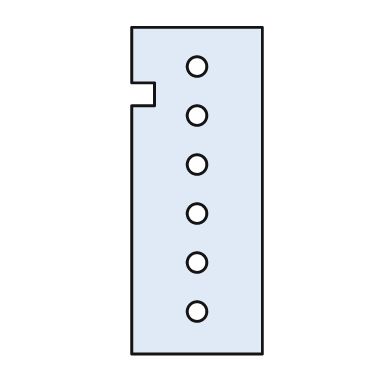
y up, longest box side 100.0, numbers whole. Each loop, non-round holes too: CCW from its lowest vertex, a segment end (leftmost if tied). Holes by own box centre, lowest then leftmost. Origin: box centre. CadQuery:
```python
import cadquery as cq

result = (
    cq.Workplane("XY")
    .moveTo(-20.0, -50.0)
    .lineTo(20.0, -50.0)
    .lineTo(20.0, 50.0)
    .lineTo(-20.0, 50.0)
    .lineTo(-20.0, 33.0)
    .lineTo(-13.0, 33.0)
    .lineTo(-13.0, 26.0)
    .lineTo(-20.0, 26.0)
    .close()
    .moveTo(0.0, -37.0)
    .circle(3.0)
    .moveTo(0.0, -22.0)
    .circle(3.0)
    .moveTo(0.0, -7.0)
    .circle(3.0)
    .moveTo(0.0, 8.0)
    .circle(3.0)
    .moveTo(0.0, 23.0)
    .circle(3.0)
    .moveTo(0.0, 38.0)
    .circle(3.0)
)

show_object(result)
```